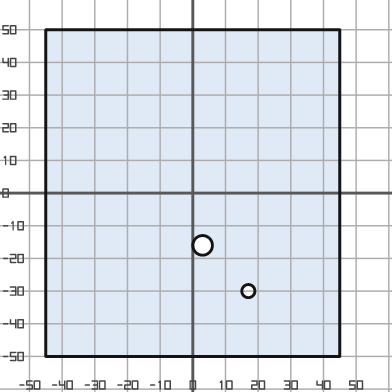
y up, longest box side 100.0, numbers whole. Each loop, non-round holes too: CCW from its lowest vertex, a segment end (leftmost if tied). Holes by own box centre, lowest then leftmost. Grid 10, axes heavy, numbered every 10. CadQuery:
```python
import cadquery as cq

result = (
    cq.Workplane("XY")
    .moveTo(-45.0, -50.0)
    .lineTo(45.0, -50.0)
    .lineTo(45.0, 50.0)
    .lineTo(-45.0, 50.0)
    .close()
    .moveTo(17.0, -30.0)
    .circle(2.0)
    .moveTo(3.0, -16.0)
    .circle(3.0)
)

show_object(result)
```